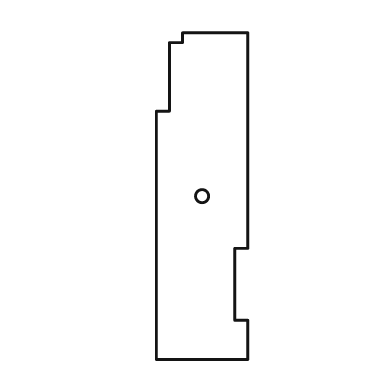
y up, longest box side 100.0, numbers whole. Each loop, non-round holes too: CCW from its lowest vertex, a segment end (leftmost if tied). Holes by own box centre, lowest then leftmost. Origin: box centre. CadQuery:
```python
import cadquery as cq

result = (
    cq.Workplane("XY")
    .moveTo(-14.0, -50.0)
    .lineTo(14.0, -50.0)
    .lineTo(14.0, -38.0)
    .lineTo(10.0, -38.0)
    .lineTo(10.0, -16.0)
    .lineTo(14.0, -16.0)
    .lineTo(14.0, 50.0)
    .lineTo(-6.0, 50.0)
    .lineTo(-6.0, 47.0)
    .lineTo(-10.0, 47.0)
    .lineTo(-10.0, 26.0)
    .lineTo(-14.0, 26.0)
    .close()
    .moveTo(0.0, 0.0)
    .circle(2.0)
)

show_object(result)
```